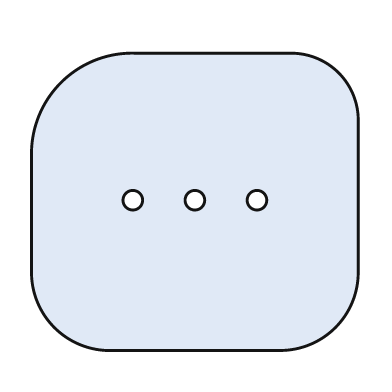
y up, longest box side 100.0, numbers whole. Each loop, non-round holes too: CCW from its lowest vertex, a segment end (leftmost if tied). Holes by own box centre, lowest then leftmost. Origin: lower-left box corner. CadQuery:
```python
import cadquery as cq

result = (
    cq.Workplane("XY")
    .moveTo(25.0, 0.0)
    .lineTo(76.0, 0.0)
    .threePointArc((93.0, 7.0), (100.0, 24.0))
    .lineTo(100.0, 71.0)
    .threePointArc((94.0, 85.0), (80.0, 91.0))
    .lineTo(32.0, 91.0)
    .threePointArc((9.0, 82.0), (0.0, 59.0))
    .lineTo(0.0, 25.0)
    .threePointArc((7.0, 7.0), (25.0, 0.0))
    .close()
    .moveTo(31.0, 46.0)
    .circle(3.0)
    .moveTo(50.0, 46.0)
    .circle(3.0)
    .moveTo(69.0, 46.0)
    .circle(3.0)
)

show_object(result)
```